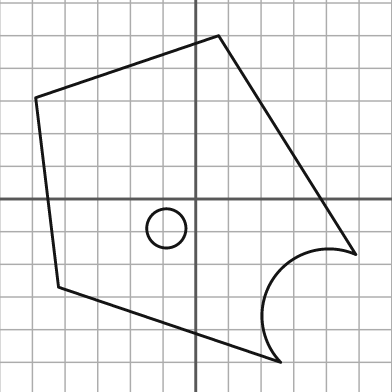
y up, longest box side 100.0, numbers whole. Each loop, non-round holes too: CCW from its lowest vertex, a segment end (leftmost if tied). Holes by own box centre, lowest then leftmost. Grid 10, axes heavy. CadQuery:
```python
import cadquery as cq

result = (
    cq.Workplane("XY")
    .moveTo(26.0, -50.0)
    .threePointArc((24.0, -24.0), (49.0, -17.0))
    .lineTo(7.0, 50.0)
    .lineTo(-49.0, 31.0)
    .lineTo(-42.0, -27.0)
    .close()
    .moveTo(-9.0, -9.0)
    .circle(6.0)
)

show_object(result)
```